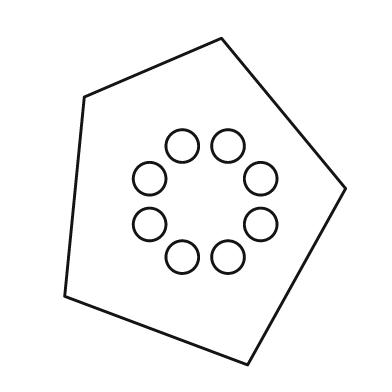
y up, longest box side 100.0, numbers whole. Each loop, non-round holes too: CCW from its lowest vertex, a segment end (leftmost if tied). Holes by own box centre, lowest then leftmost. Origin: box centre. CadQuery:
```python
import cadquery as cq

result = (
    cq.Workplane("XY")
    .moveTo(13.0, -50.0)
    .lineTo(43.0, 4.0)
    .lineTo(5.0, 50.0)
    .lineTo(-37.0, 32.0)
    .lineTo(-43.0, -29.0)
    .close()
    .moveTo(-7.0, -17.0)
    .circle(5.0)
    .moveTo(7.0, -17.0)
    .circle(5.0)
    .moveTo(-17.0, -7.0)
    .circle(5.0)
    .moveTo(17.0, -7.0)
    .circle(5.0)
    .moveTo(-17.0, 7.0)
    .circle(5.0)
    .moveTo(17.0, 7.0)
    .circle(5.0)
    .moveTo(-7.0, 17.0)
    .circle(5.0)
    .moveTo(7.0, 17.0)
    .circle(5.0)
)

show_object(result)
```